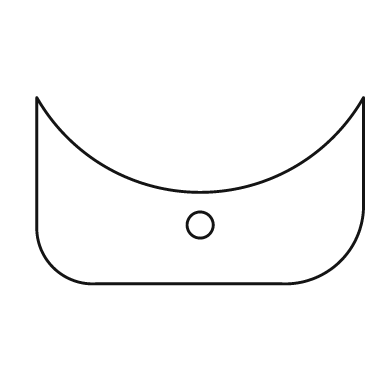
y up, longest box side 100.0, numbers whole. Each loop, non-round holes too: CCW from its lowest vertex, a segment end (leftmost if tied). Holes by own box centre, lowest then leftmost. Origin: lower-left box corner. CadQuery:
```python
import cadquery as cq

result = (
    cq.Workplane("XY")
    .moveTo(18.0, 0.0)
    .lineTo(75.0, 0.0)
    .threePointArc((93.0, 7.0), (100.0, 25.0))
    .lineTo(100.0, 57.0)
    .threePointArc((50.0, 28.0), (0.0, 57.0))
    .lineTo(0.0, 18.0)
    .threePointArc((5.0, 5.0), (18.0, 0.0))
    .close()
    .moveTo(50.0, 18.0)
    .circle(4.0)
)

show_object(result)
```